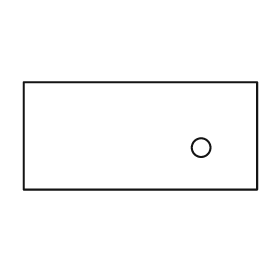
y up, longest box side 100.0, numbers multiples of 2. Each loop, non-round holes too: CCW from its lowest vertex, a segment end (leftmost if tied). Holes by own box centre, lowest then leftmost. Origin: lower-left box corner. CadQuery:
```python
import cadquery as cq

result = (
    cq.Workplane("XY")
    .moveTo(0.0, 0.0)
    .lineTo(100.0, 0.0)
    .lineTo(100.0, 46.0)
    .lineTo(0.0, 46.0)
    .close()
    .moveTo(76.0, 18.0)
    .circle(4.0)
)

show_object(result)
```